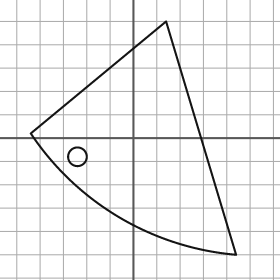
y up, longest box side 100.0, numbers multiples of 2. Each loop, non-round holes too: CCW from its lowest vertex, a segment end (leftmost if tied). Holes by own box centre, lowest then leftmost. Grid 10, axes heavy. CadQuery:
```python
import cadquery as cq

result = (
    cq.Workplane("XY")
    .moveTo(44.0, -50.0)
    .lineTo(14.0, 50.0)
    .lineTo(-44.0, 2.0)
    .threePointArc((-6.0, -34.0), (44.0, -50.0))
    .close()
    .moveTo(-24.0, -8.0)
    .circle(4.0)
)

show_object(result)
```